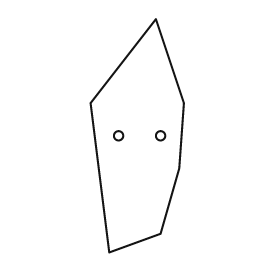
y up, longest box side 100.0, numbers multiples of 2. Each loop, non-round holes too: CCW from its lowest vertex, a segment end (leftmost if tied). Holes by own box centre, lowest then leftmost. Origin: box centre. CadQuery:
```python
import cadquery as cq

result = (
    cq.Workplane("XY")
    .moveTo(-12.0, -50.0)
    .lineTo(10.0, -42.0)
    .lineTo(18.0, -14.0)
    .lineTo(20.0, 14.0)
    .lineTo(8.0, 50.0)
    .lineTo(-20.0, 14.0)
    .close()
    .moveTo(-8.0, 0.0)
    .circle(2.0)
    .moveTo(10.0, 0.0)
    .circle(2.0)
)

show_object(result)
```